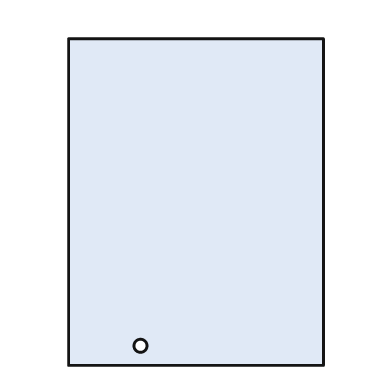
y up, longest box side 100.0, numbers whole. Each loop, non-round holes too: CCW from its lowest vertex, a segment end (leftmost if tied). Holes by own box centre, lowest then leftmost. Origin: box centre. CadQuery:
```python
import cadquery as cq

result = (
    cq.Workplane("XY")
    .moveTo(-39.0, -50.0)
    .lineTo(39.0, -50.0)
    .lineTo(39.0, 50.0)
    .lineTo(-39.0, 50.0)
    .close()
    .moveTo(-17.0, -44.0)
    .circle(2.0)
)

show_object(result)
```